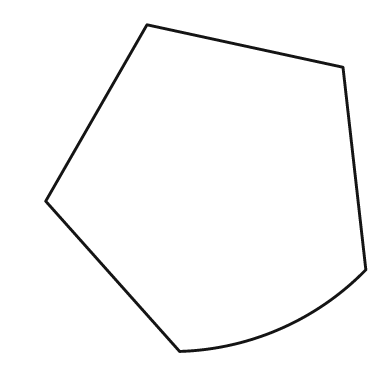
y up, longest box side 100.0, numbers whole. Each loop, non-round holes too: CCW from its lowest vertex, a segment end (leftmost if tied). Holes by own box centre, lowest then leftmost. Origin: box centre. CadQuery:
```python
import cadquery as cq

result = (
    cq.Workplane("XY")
    .moveTo(-8.0, -50.0)
    .threePointArc((23.0, -43.0), (49.0, -25.0))
    .lineTo(42.0, 37.0)
    .lineTo(-18.0, 50.0)
    .lineTo(-49.0, -4.0)
    .close()
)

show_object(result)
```